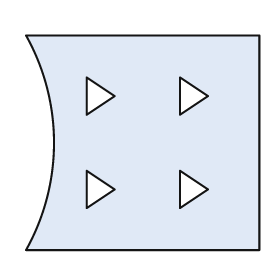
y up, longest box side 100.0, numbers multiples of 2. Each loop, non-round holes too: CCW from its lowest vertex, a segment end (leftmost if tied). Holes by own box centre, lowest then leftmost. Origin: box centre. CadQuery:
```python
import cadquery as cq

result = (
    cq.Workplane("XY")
    .moveTo(-50.0, -46.0)
    .lineTo(50.0, -46.0)
    .lineTo(50.0, 46.0)
    .lineTo(-50.0, 46.0)
    .threePointArc((-38.0, 0.0), (-50.0, -46.0))
    .close()
    .moveTo(-24.0, -28.0)
    .lineTo(-12.0, -20.0)
    .lineTo(-24.0, -12.0)
    .close()
    .moveTo(16.0, -28.0)
    .lineTo(28.0, -20.0)
    .lineTo(16.0, -12.0)
    .close()
    .moveTo(-24.0, 12.0)
    .lineTo(-12.0, 20.0)
    .lineTo(-24.0, 28.0)
    .close()
    .moveTo(16.0, 12.0)
    .lineTo(28.0, 20.0)
    .lineTo(16.0, 28.0)
    .close()
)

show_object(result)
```